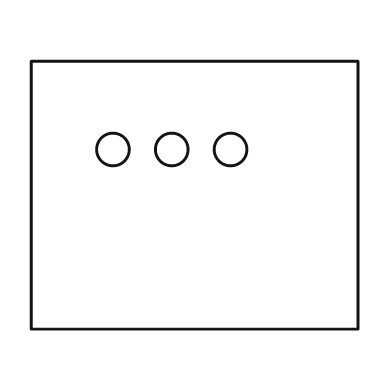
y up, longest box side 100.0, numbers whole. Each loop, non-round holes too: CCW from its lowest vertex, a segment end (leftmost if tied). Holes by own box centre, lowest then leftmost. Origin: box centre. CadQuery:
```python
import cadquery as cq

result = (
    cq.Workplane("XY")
    .moveTo(-50.0, -41.0)
    .lineTo(50.0, -41.0)
    .lineTo(50.0, 41.0)
    .lineTo(-50.0, 41.0)
    .close()
    .moveTo(-25.0, 14.0)
    .circle(5.0)
    .moveTo(-7.0, 14.0)
    .circle(5.0)
    .moveTo(11.0, 14.0)
    .circle(5.0)
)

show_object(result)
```